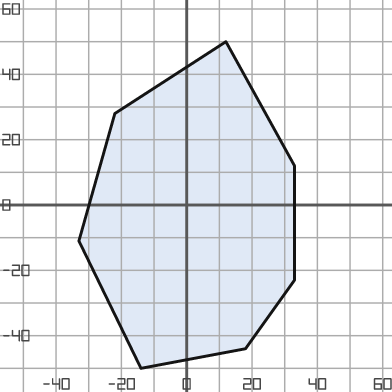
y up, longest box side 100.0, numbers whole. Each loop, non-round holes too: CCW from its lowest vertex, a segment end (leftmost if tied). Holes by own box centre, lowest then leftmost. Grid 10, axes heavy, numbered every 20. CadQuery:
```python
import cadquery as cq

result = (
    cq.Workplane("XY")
    .moveTo(-14.0, -50.0)
    .lineTo(18.0, -44.0)
    .lineTo(33.0, -23.0)
    .lineTo(33.0, 12.0)
    .lineTo(12.0, 50.0)
    .lineTo(-22.0, 28.0)
    .lineTo(-33.0, -11.0)
    .close()
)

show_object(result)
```